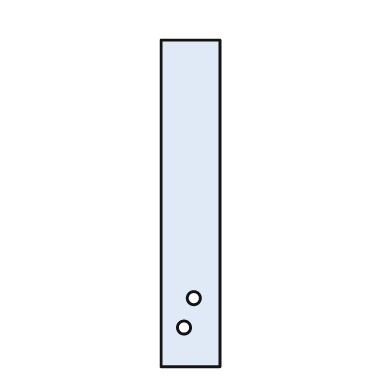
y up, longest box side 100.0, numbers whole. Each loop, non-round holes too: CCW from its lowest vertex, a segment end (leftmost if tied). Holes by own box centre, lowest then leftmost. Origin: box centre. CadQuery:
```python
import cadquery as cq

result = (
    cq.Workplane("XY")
    .moveTo(-9.0, -50.0)
    .lineTo(9.0, -50.0)
    .lineTo(9.0, 50.0)
    .lineTo(-9.0, 50.0)
    .close()
    .moveTo(-2.0, -38.0)
    .circle(2.0)
    .moveTo(1.0, -29.0)
    .circle(2.0)
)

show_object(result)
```